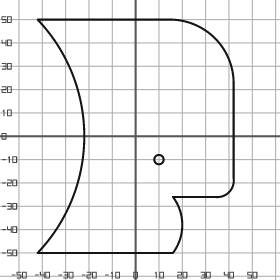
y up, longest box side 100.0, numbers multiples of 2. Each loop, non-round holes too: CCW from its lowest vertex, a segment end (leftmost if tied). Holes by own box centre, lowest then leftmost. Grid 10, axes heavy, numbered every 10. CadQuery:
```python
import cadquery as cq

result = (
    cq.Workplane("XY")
    .moveTo(-42.0, -50.0)
    .lineTo(16.0, -50.0)
    .threePointArc((20.0, -38.0), (16.0, -26.0))
    .lineTo(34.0, -26.0)
    .threePointArc((40.0, -24.0), (42.0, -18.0))
    .lineTo(42.0, 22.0)
    .threePointArc((34.0, 42.0), (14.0, 50.0))
    .lineTo(-42.0, 50.0)
    .threePointArc((-22.0, 0.0), (-42.0, -50.0))
    .close()
    .moveTo(10.0, -10.0)
    .circle(2.0)
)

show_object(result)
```